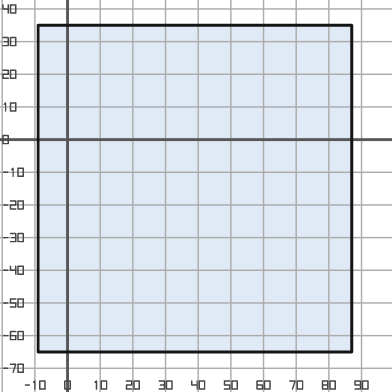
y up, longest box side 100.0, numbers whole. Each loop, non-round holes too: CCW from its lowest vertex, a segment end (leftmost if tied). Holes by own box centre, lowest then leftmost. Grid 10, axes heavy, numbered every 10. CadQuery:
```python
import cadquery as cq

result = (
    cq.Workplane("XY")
    .moveTo(-9.0, -65.0)
    .lineTo(87.0, -65.0)
    .lineTo(87.0, 35.0)
    .lineTo(-9.0, 35.0)
    .close()
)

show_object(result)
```